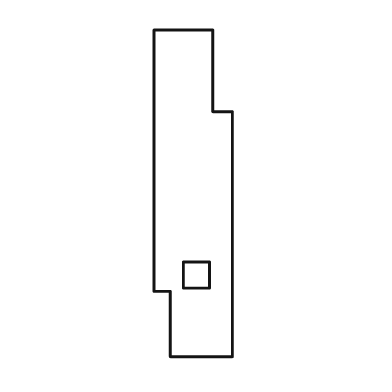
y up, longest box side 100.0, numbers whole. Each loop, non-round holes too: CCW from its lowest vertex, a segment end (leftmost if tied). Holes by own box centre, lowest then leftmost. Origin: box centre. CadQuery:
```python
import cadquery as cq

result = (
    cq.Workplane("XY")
    .moveTo(-7.0, -50.0)
    .lineTo(12.0, -50.0)
    .lineTo(12.0, 25.0)
    .lineTo(6.0, 25.0)
    .lineTo(6.0, 50.0)
    .lineTo(-12.0, 50.0)
    .lineTo(-12.0, -30.0)
    .lineTo(-7.0, -30.0)
    .close()
    .moveTo(-3.0, -29.0)
    .lineTo(5.0, -29.0)
    .lineTo(5.0, -21.0)
    .lineTo(-3.0, -21.0)
    .close()
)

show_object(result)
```